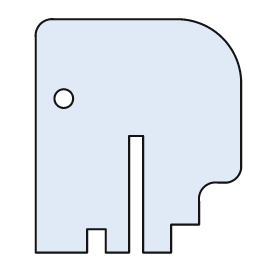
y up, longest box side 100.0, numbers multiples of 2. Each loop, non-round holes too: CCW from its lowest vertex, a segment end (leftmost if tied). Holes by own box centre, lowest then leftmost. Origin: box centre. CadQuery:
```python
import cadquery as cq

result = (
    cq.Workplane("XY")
    .moveTo(-44.0, -50.0)
    .lineTo(-22.0, -50.0)
    .lineTo(-22.0, -40.0)
    .lineTo(-14.0, -40.0)
    .lineTo(-14.0, -50.0)
    .lineTo(-4.0, -50.0)
    .lineTo(-4.0, 0.0)
    .lineTo(2.0, 0.0)
    .lineTo(2.0, -50.0)
    .lineTo(14.0, -50.0)
    .lineTo(14.0, -38.0)
    .lineTo(26.0, -38.0)
    .lineTo(26.0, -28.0)
    .threePointArc((28.0, -22.0), (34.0, -20.0))
    .lineTo(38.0, -20.0)
    .threePointArc((42.0, -18.0), (44.0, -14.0))
    .lineTo(44.0, 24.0)
    .threePointArc((36.0, 42.0), (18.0, 50.0))
    .lineTo(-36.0, 50.0)
    .threePointArc((-42.0, 48.0), (-44.0, 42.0))
    .close()
    .moveTo(-32.0, 16.0)
    .circle(4.0)
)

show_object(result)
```